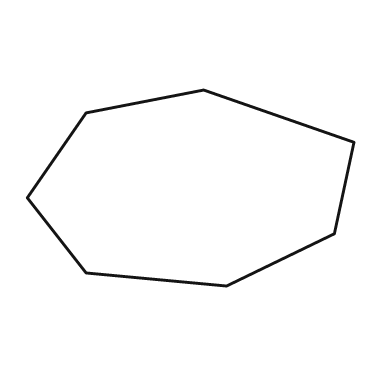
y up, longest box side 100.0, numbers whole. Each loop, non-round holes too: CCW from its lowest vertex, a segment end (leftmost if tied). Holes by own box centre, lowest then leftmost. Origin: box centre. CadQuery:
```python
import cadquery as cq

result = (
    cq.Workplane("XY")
    .moveTo(11.0, -30.0)
    .lineTo(44.0, -14.0)
    .lineTo(50.0, 14.0)
    .lineTo(4.0, 30.0)
    .lineTo(-32.0, 23.0)
    .lineTo(-50.0, -3.0)
    .lineTo(-32.0, -26.0)
    .close()
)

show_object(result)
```